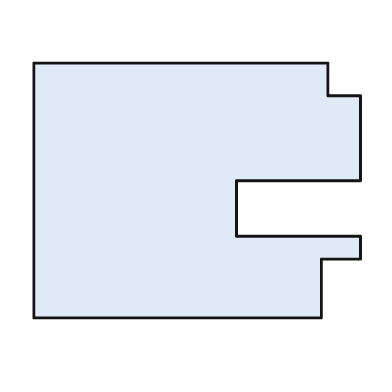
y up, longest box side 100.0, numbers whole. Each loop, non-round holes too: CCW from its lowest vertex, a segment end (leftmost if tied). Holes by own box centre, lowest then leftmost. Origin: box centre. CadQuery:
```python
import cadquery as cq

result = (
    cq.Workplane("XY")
    .moveTo(-50.0, -39.0)
    .lineTo(38.0, -39.0)
    .lineTo(38.0, -21.0)
    .lineTo(50.0, -21.0)
    .lineTo(50.0, -14.0)
    .lineTo(12.0, -14.0)
    .lineTo(12.0, 3.0)
    .lineTo(50.0, 3.0)
    .lineTo(50.0, 29.0)
    .lineTo(40.0, 29.0)
    .lineTo(40.0, 39.0)
    .lineTo(-50.0, 39.0)
    .close()
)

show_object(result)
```